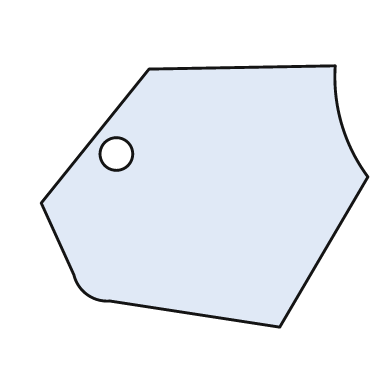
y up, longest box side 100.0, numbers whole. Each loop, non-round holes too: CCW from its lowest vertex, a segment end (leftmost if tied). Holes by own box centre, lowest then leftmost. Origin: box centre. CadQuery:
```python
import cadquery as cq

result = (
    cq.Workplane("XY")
    .moveTo(23.0, -40.0)
    .lineTo(50.0, 6.0)
    .threePointArc((42.0, 22.0), (40.0, 40.0))
    .lineTo(-17.0, 39.0)
    .lineTo(-50.0, -2.0)
    .lineTo(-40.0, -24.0)
    .threePointArc((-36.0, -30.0), (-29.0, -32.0))
    .close()
    .moveTo(-27.0, 13.0)
    .circle(5.0)
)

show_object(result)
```